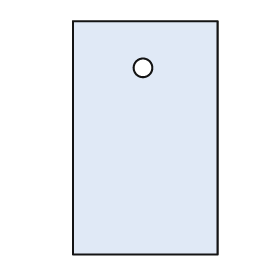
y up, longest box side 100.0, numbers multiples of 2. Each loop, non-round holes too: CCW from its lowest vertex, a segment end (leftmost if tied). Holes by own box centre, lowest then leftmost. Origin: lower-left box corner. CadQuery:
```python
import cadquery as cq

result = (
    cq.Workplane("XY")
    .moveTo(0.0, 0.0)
    .lineTo(62.0, 0.0)
    .lineTo(62.0, 100.0)
    .lineTo(0.0, 100.0)
    .close()
    .moveTo(30.0, 80.0)
    .circle(4.0)
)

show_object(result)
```